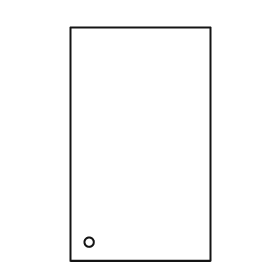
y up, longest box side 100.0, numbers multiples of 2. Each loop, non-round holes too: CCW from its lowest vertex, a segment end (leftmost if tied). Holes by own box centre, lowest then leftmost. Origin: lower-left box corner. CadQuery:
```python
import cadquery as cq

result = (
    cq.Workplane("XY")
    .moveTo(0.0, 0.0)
    .lineTo(60.0, 0.0)
    .lineTo(60.0, 100.0)
    .lineTo(0.0, 100.0)
    .close()
    .moveTo(8.0, 8.0)
    .circle(2.0)
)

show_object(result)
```